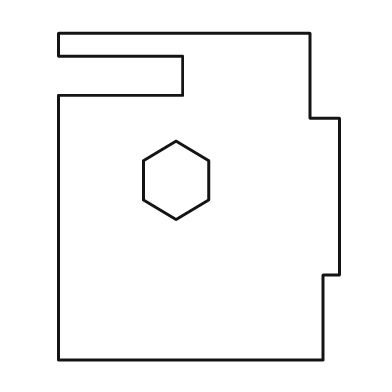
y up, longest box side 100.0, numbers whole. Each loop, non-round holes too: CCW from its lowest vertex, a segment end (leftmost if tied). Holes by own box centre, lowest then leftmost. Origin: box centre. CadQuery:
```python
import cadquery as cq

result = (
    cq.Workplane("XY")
    .moveTo(-43.0, -50.0)
    .lineTo(38.0, -50.0)
    .lineTo(38.0, -24.0)
    .lineTo(43.0, -24.0)
    .lineTo(43.0, 24.0)
    .lineTo(34.0, 24.0)
    .lineTo(34.0, 50.0)
    .lineTo(-43.0, 50.0)
    .lineTo(-43.0, 43.0)
    .lineTo(-5.0, 43.0)
    .lineTo(-5.0, 31.0)
    .lineTo(-43.0, 31.0)
    .close()
    .moveTo(-7.0, -7.0)
    .lineTo(3.0, -1.0)
    .lineTo(3.0, 11.0)
    .lineTo(-7.0, 17.0)
    .lineTo(-17.0, 11.0)
    .lineTo(-17.0, -1.0)
    .close()
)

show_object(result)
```